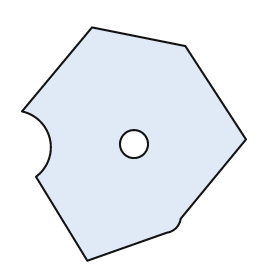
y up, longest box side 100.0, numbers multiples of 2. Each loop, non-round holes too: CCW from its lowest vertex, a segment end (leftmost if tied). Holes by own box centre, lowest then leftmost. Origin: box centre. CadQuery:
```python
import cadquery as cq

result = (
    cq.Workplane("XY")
    .moveTo(-20.0, -50.0)
    .lineTo(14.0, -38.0)
    .threePointArc((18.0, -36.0), (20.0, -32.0))
    .lineTo(48.0, 2.0)
    .lineTo(22.0, 42.0)
    .lineTo(-18.0, 50.0)
    .lineTo(-48.0, 14.0)
    .threePointArc((-36.0, 2.0), (-42.0, -14.0))
    .close()
    .moveTo(0.0, 0.0)
    .circle(6.0)
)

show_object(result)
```